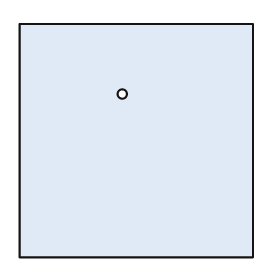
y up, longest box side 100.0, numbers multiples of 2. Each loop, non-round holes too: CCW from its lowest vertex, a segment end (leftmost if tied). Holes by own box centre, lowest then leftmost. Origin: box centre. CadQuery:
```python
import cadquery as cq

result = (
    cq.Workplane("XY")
    .moveTo(-50.0, -50.0)
    .lineTo(50.0, -50.0)
    .lineTo(50.0, 50.0)
    .lineTo(-50.0, 50.0)
    .close()
    .moveTo(-6.0, 20.0)
    .circle(2.0)
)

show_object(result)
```